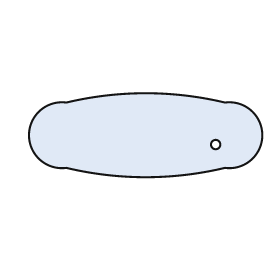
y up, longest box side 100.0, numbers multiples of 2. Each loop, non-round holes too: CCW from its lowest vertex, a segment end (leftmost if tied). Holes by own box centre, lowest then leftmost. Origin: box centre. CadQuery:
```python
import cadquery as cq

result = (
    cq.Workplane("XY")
    .moveTo(-34.0, -14.0)
    .threePointArc((0.0, -18.0), (34.0, -14.0))
    .threePointArc((50.0, 0.0), (34.0, 14.0))
    .threePointArc((0.0, 18.0), (-34.0, 14.0))
    .threePointArc((-50.0, 0.0), (-34.0, -14.0))
    .close()
    .moveTo(30.0, -4.0)
    .circle(2.0)
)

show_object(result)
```